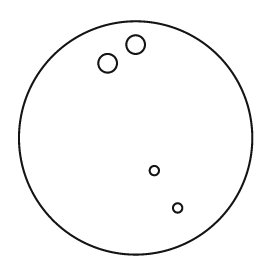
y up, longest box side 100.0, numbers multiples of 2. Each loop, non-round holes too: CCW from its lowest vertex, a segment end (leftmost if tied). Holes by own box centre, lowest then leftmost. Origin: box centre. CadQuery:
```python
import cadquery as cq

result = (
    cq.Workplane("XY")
    .moveTo(0.0, 0.0)
    .circle(50.0)
    .moveTo(18.0, -30.0)
    .circle(2.0)
    .moveTo(8.0, -14.0)
    .circle(2.0)
    .moveTo(-12.0, 32.0)
    .circle(4.0)
    .moveTo(0.0, 40.0)
    .circle(4.0)
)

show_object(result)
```